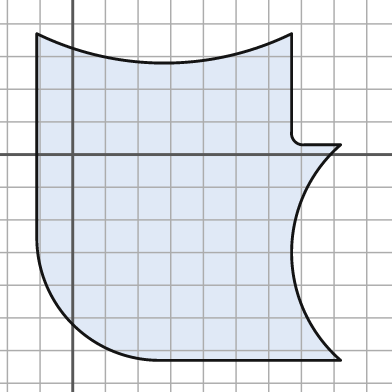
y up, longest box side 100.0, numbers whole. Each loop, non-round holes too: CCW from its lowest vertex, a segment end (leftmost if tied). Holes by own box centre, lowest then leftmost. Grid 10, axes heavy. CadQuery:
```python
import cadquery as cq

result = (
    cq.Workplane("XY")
    .moveTo(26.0, -63.0)
    .lineTo(82.0, -63.0)
    .threePointArc((67.0, -30.0), (82.0, 3.0))
    .lineTo(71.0, 3.0)
    .threePointArc((68.0, 4.0), (67.0, 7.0))
    .lineTo(67.0, 37.0)
    .threePointArc((28.0, 28.0), (-11.0, 37.0))
    .lineTo(-11.0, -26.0)
    .threePointArc((0.0, -52.0), (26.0, -63.0))
    .close()
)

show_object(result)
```